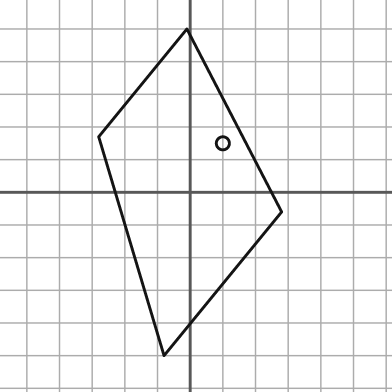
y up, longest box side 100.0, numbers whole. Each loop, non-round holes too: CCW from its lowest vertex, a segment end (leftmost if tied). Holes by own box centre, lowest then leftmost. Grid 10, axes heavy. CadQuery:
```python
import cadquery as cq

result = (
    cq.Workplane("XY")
    .moveTo(-8.0, -50.0)
    .lineTo(28.0, -6.0)
    .lineTo(-1.0, 50.0)
    .lineTo(-28.0, 17.0)
    .close()
    .moveTo(10.0, 15.0)
    .circle(2.0)
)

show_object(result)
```